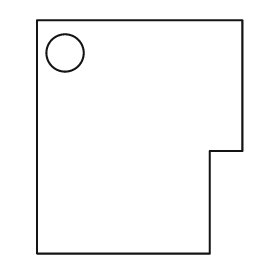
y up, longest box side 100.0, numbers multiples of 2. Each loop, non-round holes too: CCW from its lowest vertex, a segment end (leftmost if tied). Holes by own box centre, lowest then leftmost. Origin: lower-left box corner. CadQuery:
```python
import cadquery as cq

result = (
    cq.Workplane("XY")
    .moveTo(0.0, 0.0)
    .lineTo(74.0, 0.0)
    .lineTo(74.0, 44.0)
    .lineTo(88.0, 44.0)
    .lineTo(88.0, 100.0)
    .lineTo(0.0, 100.0)
    .close()
    .moveTo(12.0, 86.0)
    .circle(8.0)
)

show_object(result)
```